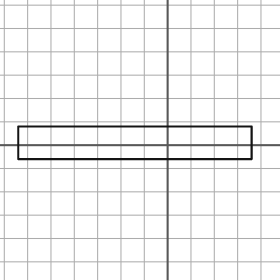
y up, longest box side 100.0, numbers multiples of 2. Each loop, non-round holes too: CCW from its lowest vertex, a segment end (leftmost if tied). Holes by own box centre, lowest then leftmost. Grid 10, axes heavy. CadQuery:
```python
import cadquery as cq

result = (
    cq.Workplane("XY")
    .moveTo(-64.0, -6.0)
    .lineTo(36.0, -6.0)
    .lineTo(36.0, 8.0)
    .lineTo(-64.0, 8.0)
    .close()
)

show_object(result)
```